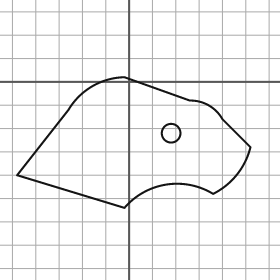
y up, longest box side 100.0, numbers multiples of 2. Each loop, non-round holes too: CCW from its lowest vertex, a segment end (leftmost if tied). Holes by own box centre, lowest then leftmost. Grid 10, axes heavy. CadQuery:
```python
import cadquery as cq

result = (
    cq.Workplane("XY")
    .moveTo(-2.0, -54.0)
    .threePointArc((16.0, -44.0), (36.0, -48.0))
    .threePointArc((46.0, -40.0), (52.0, -28.0))
    .lineTo(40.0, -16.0)
    .threePointArc((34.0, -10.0), (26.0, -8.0))
    .lineTo(-2.0, 2.0)
    .threePointArc((-16.0, -2.0), (-26.0, -12.0))
    .lineTo(-48.0, -40.0)
    .close()
    .moveTo(18.0, -22.0)
    .circle(4.0)
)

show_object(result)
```